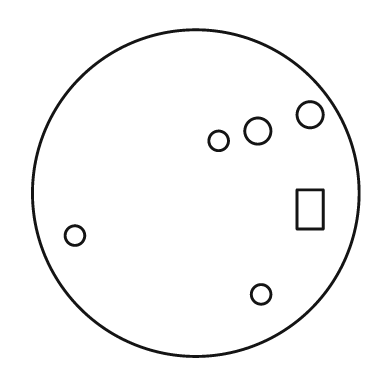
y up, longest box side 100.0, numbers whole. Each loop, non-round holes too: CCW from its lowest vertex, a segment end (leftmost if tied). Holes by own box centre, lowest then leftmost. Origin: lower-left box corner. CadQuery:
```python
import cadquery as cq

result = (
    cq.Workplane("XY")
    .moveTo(50.0, 50.0)
    .circle(50.0)
    .moveTo(70.0, 19.0)
    .circle(3.0)
    .moveTo(13.0, 37.0)
    .circle(3.0)
    .moveTo(81.0, 39.0)
    .lineTo(89.0, 39.0)
    .lineTo(89.0, 51.0)
    .lineTo(81.0, 51.0)
    .close()
    .moveTo(57.0, 66.0)
    .circle(3.0)
    .moveTo(69.0, 69.0)
    .circle(4.0)
    .moveTo(85.0, 74.0)
    .circle(4.0)
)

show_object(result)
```